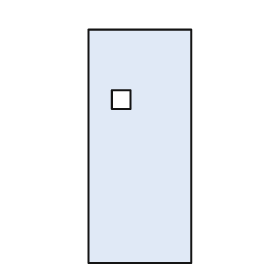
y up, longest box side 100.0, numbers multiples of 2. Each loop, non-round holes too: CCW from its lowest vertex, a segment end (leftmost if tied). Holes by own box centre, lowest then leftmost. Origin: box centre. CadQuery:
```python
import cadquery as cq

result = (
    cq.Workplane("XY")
    .moveTo(-22.0, -50.0)
    .lineTo(22.0, -50.0)
    .lineTo(22.0, 50.0)
    .lineTo(-22.0, 50.0)
    .close()
    .moveTo(-12.0, 16.0)
    .lineTo(-4.0, 16.0)
    .lineTo(-4.0, 24.0)
    .lineTo(-12.0, 24.0)
    .close()
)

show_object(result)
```